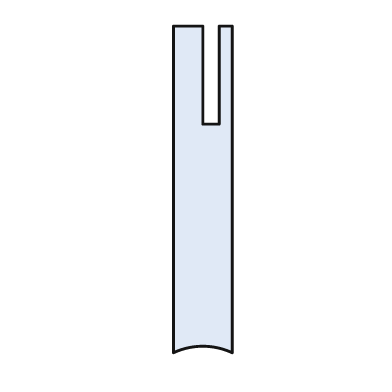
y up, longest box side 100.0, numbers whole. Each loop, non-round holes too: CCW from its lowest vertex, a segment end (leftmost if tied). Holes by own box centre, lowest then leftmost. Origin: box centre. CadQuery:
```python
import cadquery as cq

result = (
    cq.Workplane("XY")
    .moveTo(-9.0, -50.0)
    .threePointArc((0.0, -48.0), (9.0, -50.0))
    .lineTo(9.0, 50.0)
    .lineTo(5.0, 50.0)
    .lineTo(5.0, 20.0)
    .lineTo(0.0, 20.0)
    .lineTo(0.0, 50.0)
    .lineTo(-9.0, 50.0)
    .close()
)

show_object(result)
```